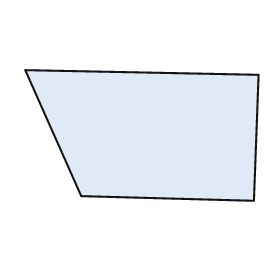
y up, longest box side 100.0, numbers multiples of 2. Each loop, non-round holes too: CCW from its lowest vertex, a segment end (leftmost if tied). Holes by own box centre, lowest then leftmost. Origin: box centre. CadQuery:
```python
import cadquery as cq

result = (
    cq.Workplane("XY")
    .moveTo(48.0, -28.0)
    .lineTo(50.0, 26.0)
    .lineTo(-50.0, 28.0)
    .lineTo(-26.0, -26.0)
    .close()
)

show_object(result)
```